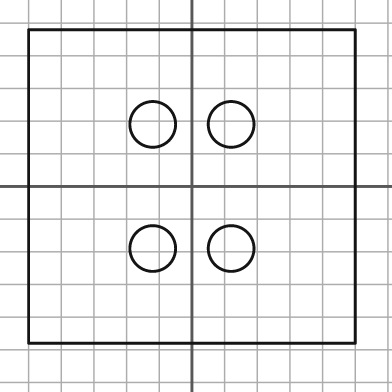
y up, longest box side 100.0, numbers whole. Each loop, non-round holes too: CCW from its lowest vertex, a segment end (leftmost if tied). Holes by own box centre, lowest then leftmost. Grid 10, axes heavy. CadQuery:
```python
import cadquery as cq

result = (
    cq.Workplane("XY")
    .moveTo(-50.0, -48.0)
    .lineTo(50.0, -48.0)
    .lineTo(50.0, 48.0)
    .lineTo(-50.0, 48.0)
    .close()
    .moveTo(-12.0, -19.0)
    .circle(7.0)
    .moveTo(12.0, -19.0)
    .circle(7.0)
    .moveTo(-12.0, 19.0)
    .circle(7.0)
    .moveTo(12.0, 19.0)
    .circle(7.0)
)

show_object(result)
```